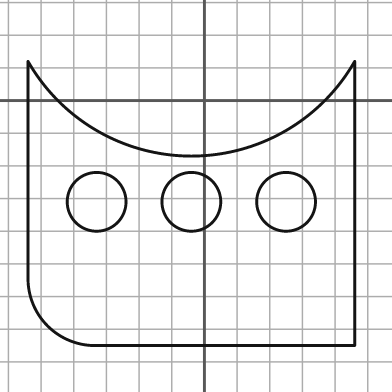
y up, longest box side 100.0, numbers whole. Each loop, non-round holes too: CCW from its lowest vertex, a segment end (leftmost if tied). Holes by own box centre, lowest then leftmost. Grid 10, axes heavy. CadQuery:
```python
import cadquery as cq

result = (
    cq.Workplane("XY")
    .moveTo(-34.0, -75.0)
    .lineTo(46.0, -75.0)
    .lineTo(46.0, 12.0)
    .threePointArc((-4.0, -17.0), (-54.0, 12.0))
    .lineTo(-54.0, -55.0)
    .threePointArc((-48.0, -69.0), (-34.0, -75.0))
    .close()
    .moveTo(-33.0, -31.0)
    .circle(9.0)
    .moveTo(-4.0, -31.0)
    .circle(9.0)
    .moveTo(25.0, -31.0)
    .circle(9.0)
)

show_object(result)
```